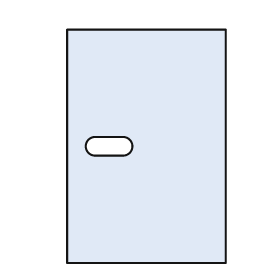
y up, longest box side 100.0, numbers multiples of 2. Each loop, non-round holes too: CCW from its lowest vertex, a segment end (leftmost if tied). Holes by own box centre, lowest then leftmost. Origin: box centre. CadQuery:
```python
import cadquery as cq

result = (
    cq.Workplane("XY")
    .moveTo(-34.0, -50.0)
    .lineTo(34.0, -50.0)
    .lineTo(34.0, 50.0)
    .lineTo(-34.0, 50.0)
    .close()
    .moveTo(-22.0, -4.0)
    .lineTo(-10.0, -4.0)
    .threePointArc((-6.0, 0.0), (-10.0, 4.0))
    .lineTo(-22.0, 4.0)
    .threePointArc((-26.0, 0.0), (-22.0, -4.0))
    .close()
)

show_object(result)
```